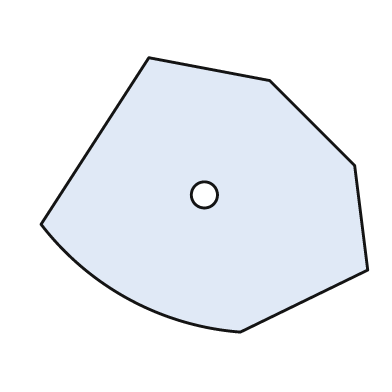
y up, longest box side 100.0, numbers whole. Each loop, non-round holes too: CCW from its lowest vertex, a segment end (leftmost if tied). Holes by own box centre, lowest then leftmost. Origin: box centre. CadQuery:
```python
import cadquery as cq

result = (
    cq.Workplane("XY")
    .moveTo(11.0, -42.0)
    .lineTo(50.0, -23.0)
    .lineTo(46.0, 9.0)
    .lineTo(20.0, 35.0)
    .lineTo(-17.0, 42.0)
    .lineTo(-50.0, -9.0)
    .threePointArc((-23.0, -32.0), (11.0, -42.0))
    .close()
    .moveTo(0.0, 0.0)
    .circle(4.0)
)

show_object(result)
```